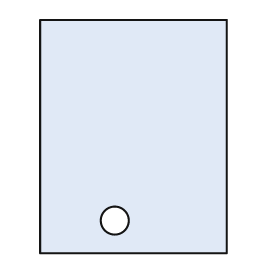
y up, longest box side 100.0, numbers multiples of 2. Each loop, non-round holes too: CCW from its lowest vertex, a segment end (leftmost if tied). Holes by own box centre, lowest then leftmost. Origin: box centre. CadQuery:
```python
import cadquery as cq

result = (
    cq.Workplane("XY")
    .moveTo(-40.0, -50.0)
    .lineTo(40.0, -50.0)
    .lineTo(40.0, 50.0)
    .lineTo(-40.0, 50.0)
    .close()
    .moveTo(-8.0, -36.0)
    .circle(6.0)
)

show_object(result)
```